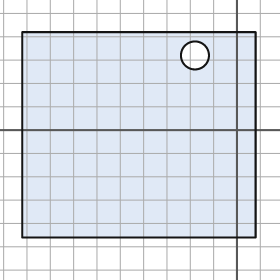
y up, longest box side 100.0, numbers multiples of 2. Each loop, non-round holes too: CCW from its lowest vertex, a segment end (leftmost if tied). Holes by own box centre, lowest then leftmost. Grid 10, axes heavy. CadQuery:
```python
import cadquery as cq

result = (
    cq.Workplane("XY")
    .moveTo(-92.0, -46.0)
    .lineTo(8.0, -46.0)
    .lineTo(8.0, 42.0)
    .lineTo(-92.0, 42.0)
    .close()
    .moveTo(-18.0, 32.0)
    .circle(6.0)
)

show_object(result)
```